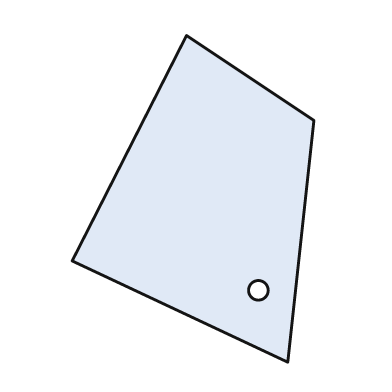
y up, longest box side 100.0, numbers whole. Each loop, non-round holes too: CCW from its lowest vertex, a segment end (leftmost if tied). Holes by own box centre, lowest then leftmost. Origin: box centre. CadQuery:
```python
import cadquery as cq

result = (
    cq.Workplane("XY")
    .moveTo(29.0, -50.0)
    .lineTo(37.0, 24.0)
    .lineTo(-2.0, 50.0)
    .lineTo(-37.0, -19.0)
    .close()
    .moveTo(20.0, -28.0)
    .circle(3.0)
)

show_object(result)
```